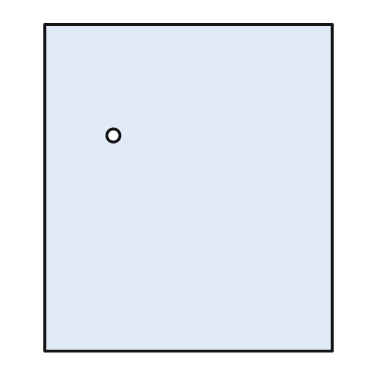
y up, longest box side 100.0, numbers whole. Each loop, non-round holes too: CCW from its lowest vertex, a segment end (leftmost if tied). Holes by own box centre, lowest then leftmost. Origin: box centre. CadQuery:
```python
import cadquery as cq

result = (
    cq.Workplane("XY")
    .moveTo(-44.0, -50.0)
    .lineTo(44.0, -50.0)
    .lineTo(44.0, 50.0)
    .lineTo(-44.0, 50.0)
    .close()
    .moveTo(-23.0, 16.0)
    .circle(2.0)
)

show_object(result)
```